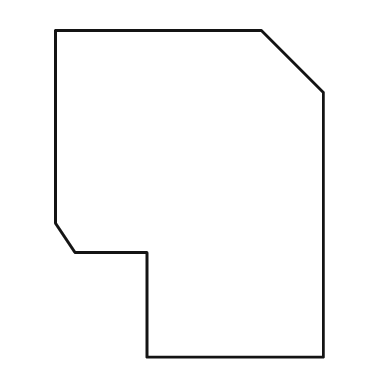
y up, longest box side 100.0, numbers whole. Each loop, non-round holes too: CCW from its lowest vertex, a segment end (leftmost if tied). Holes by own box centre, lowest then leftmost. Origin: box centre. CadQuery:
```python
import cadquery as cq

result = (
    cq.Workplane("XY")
    .moveTo(-13.0, -50.0)
    .lineTo(41.0, -50.0)
    .lineTo(41.0, 31.0)
    .lineTo(22.0, 50.0)
    .lineTo(-41.0, 50.0)
    .lineTo(-41.0, -9.0)
    .lineTo(-35.0, -18.0)
    .lineTo(-13.0, -18.0)
    .close()
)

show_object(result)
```